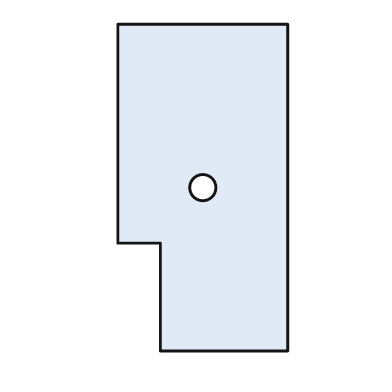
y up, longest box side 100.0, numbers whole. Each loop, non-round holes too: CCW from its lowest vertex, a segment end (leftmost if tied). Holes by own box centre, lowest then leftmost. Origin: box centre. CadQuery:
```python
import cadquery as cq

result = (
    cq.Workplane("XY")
    .moveTo(-13.0, -50.0)
    .lineTo(26.0, -50.0)
    .lineTo(26.0, 50.0)
    .lineTo(-26.0, 50.0)
    .lineTo(-26.0, -17.0)
    .lineTo(-13.0, -17.0)
    .close()
    .moveTo(0.0, 0.0)
    .circle(4.0)
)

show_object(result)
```